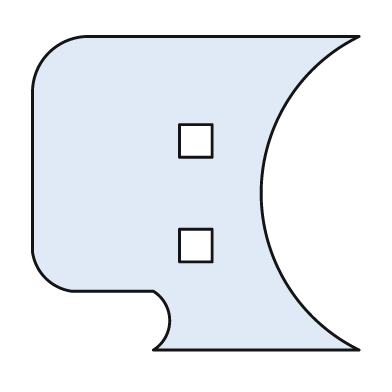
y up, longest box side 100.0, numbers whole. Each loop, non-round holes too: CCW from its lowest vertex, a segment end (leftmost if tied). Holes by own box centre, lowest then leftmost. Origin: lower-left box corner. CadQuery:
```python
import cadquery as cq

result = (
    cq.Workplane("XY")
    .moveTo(37.0, 0.0)
    .lineTo(100.0, 0.0)
    .threePointArc((70.0, 48.0), (100.0, 96.0))
    .lineTo(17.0, 96.0)
    .threePointArc((5.0, 91.0), (0.0, 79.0))
    .lineTo(0.0, 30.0)
    .threePointArc((4.0, 22.0), (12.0, 18.0))
    .lineTo(37.0, 18.0)
    .threePointArc((42.0, 9.0), (37.0, 0.0))
    .close()
    .moveTo(45.0, 27.0)
    .lineTo(55.0, 27.0)
    .lineTo(55.0, 37.0)
    .lineTo(45.0, 37.0)
    .close()
    .moveTo(45.0, 59.0)
    .lineTo(55.0, 59.0)
    .lineTo(55.0, 69.0)
    .lineTo(45.0, 69.0)
    .close()
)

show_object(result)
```